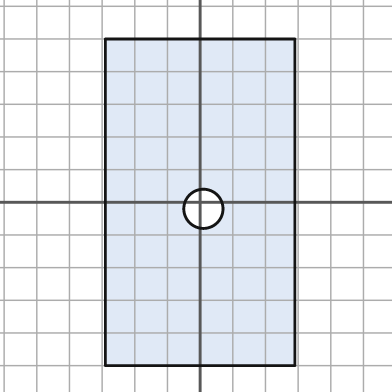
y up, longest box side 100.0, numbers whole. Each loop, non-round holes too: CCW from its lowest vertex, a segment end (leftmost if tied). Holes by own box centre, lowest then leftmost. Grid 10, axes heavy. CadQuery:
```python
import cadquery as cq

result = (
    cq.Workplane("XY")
    .moveTo(-29.0, -50.0)
    .lineTo(29.0, -50.0)
    .lineTo(29.0, 50.0)
    .lineTo(-29.0, 50.0)
    .close()
    .moveTo(1.0, -2.0)
    .circle(6.0)
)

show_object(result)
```